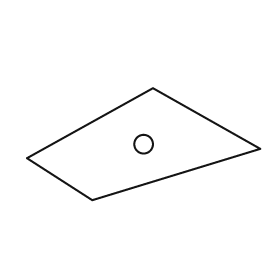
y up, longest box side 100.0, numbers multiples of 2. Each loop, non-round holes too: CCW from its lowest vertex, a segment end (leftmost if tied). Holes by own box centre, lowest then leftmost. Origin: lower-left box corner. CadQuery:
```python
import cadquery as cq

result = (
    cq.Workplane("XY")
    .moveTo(28.0, 0.0)
    .lineTo(100.0, 22.0)
    .lineTo(54.0, 48.0)
    .lineTo(0.0, 18.0)
    .close()
    .moveTo(50.0, 24.0)
    .circle(4.0)
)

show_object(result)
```